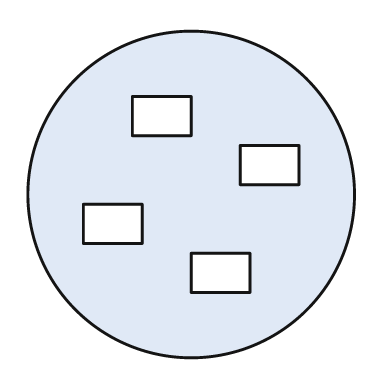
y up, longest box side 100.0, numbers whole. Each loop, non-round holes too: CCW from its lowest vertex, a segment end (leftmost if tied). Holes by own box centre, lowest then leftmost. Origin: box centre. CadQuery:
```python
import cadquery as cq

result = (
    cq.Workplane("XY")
    .moveTo(0.0, 0.0)
    .circle(50.0)
    .moveTo(0.0, -30.0)
    .lineTo(18.0, -30.0)
    .lineTo(18.0, -18.0)
    .lineTo(0.0, -18.0)
    .close()
    .moveTo(-33.0, -15.0)
    .lineTo(-15.0, -15.0)
    .lineTo(-15.0, -3.0)
    .lineTo(-33.0, -3.0)
    .close()
    .moveTo(15.0, 3.0)
    .lineTo(33.0, 3.0)
    .lineTo(33.0, 15.0)
    .lineTo(15.0, 15.0)
    .close()
    .moveTo(-18.0, 18.0)
    .lineTo(0.0, 18.0)
    .lineTo(0.0, 30.0)
    .lineTo(-18.0, 30.0)
    .close()
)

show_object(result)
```